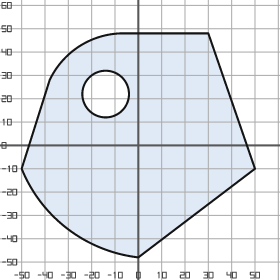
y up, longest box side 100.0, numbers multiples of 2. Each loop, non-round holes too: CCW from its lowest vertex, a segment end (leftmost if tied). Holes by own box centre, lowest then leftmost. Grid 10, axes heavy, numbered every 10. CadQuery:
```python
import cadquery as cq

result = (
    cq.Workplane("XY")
    .moveTo(0.0, -48.0)
    .lineTo(50.0, -10.0)
    .lineTo(30.0, 48.0)
    .lineTo(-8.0, 48.0)
    .threePointArc((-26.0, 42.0), (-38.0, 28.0))
    .lineTo(-50.0, -10.0)
    .threePointArc((-30.0, -36.0), (0.0, -48.0))
    .close()
    .moveTo(-14.0, 22.0)
    .circle(10.0)
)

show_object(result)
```